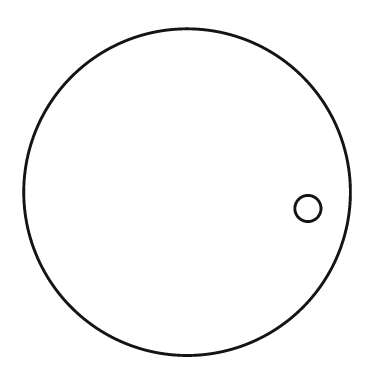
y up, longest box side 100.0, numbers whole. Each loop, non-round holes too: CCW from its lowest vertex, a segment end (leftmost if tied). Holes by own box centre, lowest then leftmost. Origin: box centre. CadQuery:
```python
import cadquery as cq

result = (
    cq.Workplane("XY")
    .moveTo(0.0, 0.0)
    .circle(50.0)
    .moveTo(37.0, -5.0)
    .circle(4.0)
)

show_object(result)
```